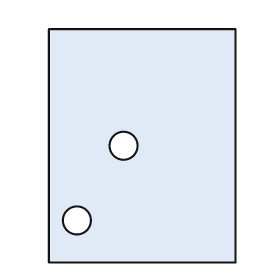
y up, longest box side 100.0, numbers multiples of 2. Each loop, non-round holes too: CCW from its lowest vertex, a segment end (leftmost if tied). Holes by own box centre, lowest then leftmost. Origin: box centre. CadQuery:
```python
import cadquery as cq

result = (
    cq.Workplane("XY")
    .moveTo(-40.0, -50.0)
    .lineTo(40.0, -50.0)
    .lineTo(40.0, 50.0)
    .lineTo(-40.0, 50.0)
    .close()
    .moveTo(-28.0, -32.0)
    .circle(6.0)
    .moveTo(-8.0, 0.0)
    .circle(6.0)
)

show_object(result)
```